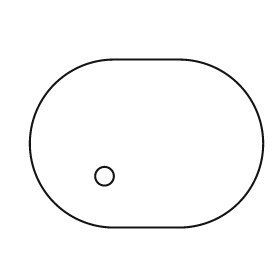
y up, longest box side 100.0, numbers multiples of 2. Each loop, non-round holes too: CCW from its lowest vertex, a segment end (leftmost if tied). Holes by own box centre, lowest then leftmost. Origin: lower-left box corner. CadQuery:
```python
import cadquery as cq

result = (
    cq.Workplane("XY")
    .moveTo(36.0, 0.0)
    .lineTo(64.0, 0.0)
    .threePointArc((100.0, 36.0), (64.0, 72.0))
    .lineTo(36.0, 72.0)
    .threePointArc((0.0, 36.0), (36.0, 0.0))
    .close()
    .moveTo(32.0, 22.0)
    .circle(4.0)
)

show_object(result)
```